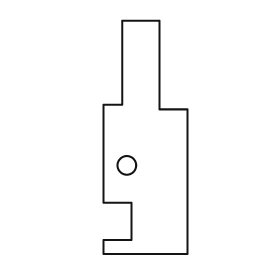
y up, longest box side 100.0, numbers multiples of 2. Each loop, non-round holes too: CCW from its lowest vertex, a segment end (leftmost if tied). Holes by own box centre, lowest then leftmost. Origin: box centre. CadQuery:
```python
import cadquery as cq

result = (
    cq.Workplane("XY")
    .moveTo(-18.0, -50.0)
    .lineTo(18.0, -50.0)
    .lineTo(18.0, 12.0)
    .lineTo(6.0, 12.0)
    .lineTo(6.0, 50.0)
    .lineTo(-10.0, 50.0)
    .lineTo(-10.0, 14.0)
    .lineTo(-18.0, 14.0)
    .lineTo(-18.0, -28.0)
    .lineTo(-6.0, -28.0)
    .lineTo(-6.0, -44.0)
    .lineTo(-18.0, -44.0)
    .close()
    .moveTo(-8.0, -12.0)
    .circle(4.0)
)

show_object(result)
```